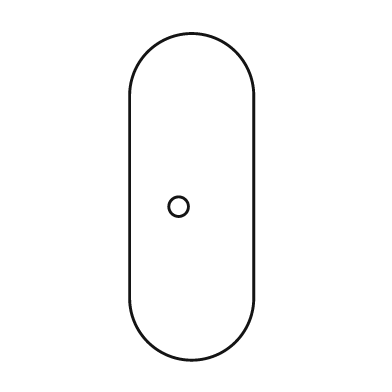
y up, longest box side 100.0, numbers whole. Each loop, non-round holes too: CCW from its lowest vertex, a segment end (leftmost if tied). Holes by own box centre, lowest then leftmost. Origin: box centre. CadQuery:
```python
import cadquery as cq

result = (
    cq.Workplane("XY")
    .moveTo(-19.0, -31.0)
    .threePointArc((0.0, -50.0), (19.0, -31.0))
    .lineTo(19.0, 31.0)
    .threePointArc((0.0, 50.0), (-19.0, 31.0))
    .close()
    .moveTo(-4.0, -3.0)
    .circle(3.0)
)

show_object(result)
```